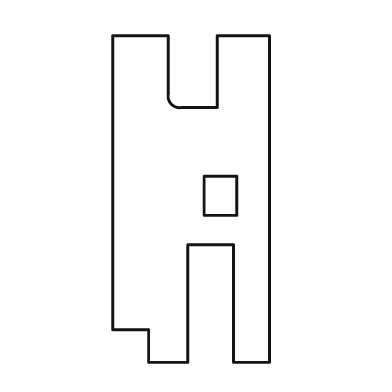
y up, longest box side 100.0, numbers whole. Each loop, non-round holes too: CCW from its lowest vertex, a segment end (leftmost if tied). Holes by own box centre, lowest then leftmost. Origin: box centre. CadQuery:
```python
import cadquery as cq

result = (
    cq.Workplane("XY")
    .moveTo(-13.0, -50.0)
    .lineTo(-1.0, -50.0)
    .lineTo(-1.0, -14.0)
    .lineTo(13.0, -14.0)
    .lineTo(13.0, -50.0)
    .lineTo(24.0, -50.0)
    .lineTo(24.0, 50.0)
    .lineTo(8.0, 50.0)
    .lineTo(8.0, 28.0)
    .lineTo(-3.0, 28.0)
    .threePointArc((-6.0, 29.0), (-7.0, 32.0))
    .lineTo(-7.0, 50.0)
    .lineTo(-24.0, 50.0)
    .lineTo(-24.0, -40.0)
    .lineTo(-13.0, -40.0)
    .close()
    .moveTo(4.0, -5.0)
    .lineTo(14.0, -5.0)
    .lineTo(14.0, 7.0)
    .lineTo(4.0, 7.0)
    .close()
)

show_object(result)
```